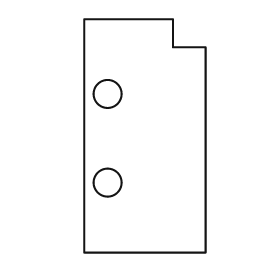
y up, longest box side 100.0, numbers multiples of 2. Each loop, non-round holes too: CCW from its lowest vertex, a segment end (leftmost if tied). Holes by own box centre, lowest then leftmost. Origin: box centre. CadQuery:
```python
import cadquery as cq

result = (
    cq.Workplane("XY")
    .moveTo(-26.0, -50.0)
    .lineTo(26.0, -50.0)
    .lineTo(26.0, 38.0)
    .lineTo(12.0, 38.0)
    .lineTo(12.0, 50.0)
    .lineTo(-26.0, 50.0)
    .close()
    .moveTo(-16.0, -20.0)
    .circle(6.0)
    .moveTo(-16.0, 18.0)
    .circle(6.0)
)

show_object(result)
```